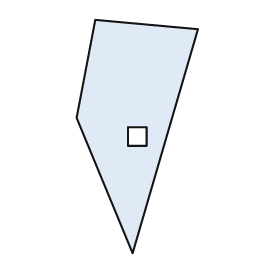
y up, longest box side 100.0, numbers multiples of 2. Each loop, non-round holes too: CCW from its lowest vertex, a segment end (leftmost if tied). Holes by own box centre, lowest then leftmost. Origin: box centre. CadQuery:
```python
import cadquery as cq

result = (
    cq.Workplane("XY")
    .moveTo(-2.0, -50.0)
    .lineTo(26.0, 46.0)
    .lineTo(-18.0, 50.0)
    .lineTo(-26.0, 8.0)
    .close()
    .moveTo(-4.0, -4.0)
    .lineTo(4.0, -4.0)
    .lineTo(4.0, 4.0)
    .lineTo(-4.0, 4.0)
    .close()
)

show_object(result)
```